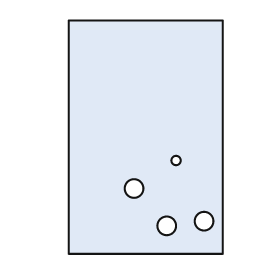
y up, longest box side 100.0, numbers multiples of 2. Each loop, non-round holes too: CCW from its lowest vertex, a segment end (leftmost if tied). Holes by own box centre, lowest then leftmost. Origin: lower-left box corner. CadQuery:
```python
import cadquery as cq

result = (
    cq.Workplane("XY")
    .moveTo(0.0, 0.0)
    .lineTo(66.0, 0.0)
    .lineTo(66.0, 100.0)
    .lineTo(0.0, 100.0)
    .close()
    .moveTo(42.0, 12.0)
    .circle(4.0)
    .moveTo(58.0, 14.0)
    .circle(4.0)
    .moveTo(28.0, 28.0)
    .circle(4.0)
    .moveTo(46.0, 40.0)
    .circle(2.0)
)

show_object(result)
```